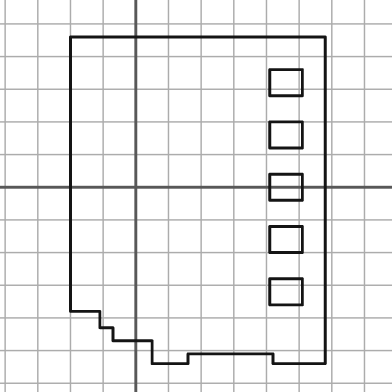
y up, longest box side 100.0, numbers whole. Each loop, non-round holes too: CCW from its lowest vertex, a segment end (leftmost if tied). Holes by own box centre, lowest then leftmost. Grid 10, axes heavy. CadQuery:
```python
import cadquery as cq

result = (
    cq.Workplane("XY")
    .moveTo(5.0, -54.0)
    .lineTo(16.0, -54.0)
    .lineTo(16.0, -51.0)
    .lineTo(42.0, -51.0)
    .lineTo(42.0, -54.0)
    .lineTo(58.0, -54.0)
    .lineTo(58.0, 46.0)
    .lineTo(-20.0, 46.0)
    .lineTo(-20.0, -38.0)
    .lineTo(-11.0, -38.0)
    .lineTo(-11.0, -43.0)
    .lineTo(-7.0, -43.0)
    .lineTo(-7.0, -47.0)
    .lineTo(5.0, -47.0)
    .close()
    .moveTo(41.0, -36.0)
    .lineTo(51.0, -36.0)
    .lineTo(51.0, -28.0)
    .lineTo(41.0, -28.0)
    .close()
    .moveTo(41.0, -20.0)
    .lineTo(51.0, -20.0)
    .lineTo(51.0, -12.0)
    .lineTo(41.0, -12.0)
    .close()
    .moveTo(41.0, -4.0)
    .lineTo(51.0, -4.0)
    .lineTo(51.0, 4.0)
    .lineTo(41.0, 4.0)
    .close()
    .moveTo(41.0, 12.0)
    .lineTo(51.0, 12.0)
    .lineTo(51.0, 20.0)
    .lineTo(41.0, 20.0)
    .close()
    .moveTo(41.0, 28.0)
    .lineTo(51.0, 28.0)
    .lineTo(51.0, 36.0)
    .lineTo(41.0, 36.0)
    .close()
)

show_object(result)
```